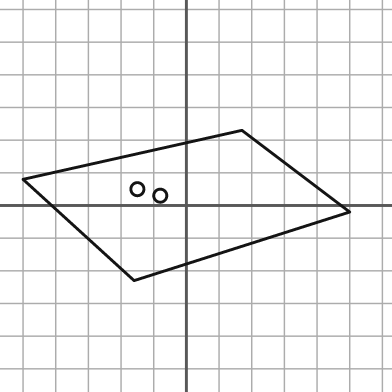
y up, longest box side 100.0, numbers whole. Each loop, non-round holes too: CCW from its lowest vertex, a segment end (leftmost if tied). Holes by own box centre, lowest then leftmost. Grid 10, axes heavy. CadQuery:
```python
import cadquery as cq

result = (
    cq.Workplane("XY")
    .moveTo(-16.0, -23.0)
    .lineTo(50.0, -2.0)
    .lineTo(17.0, 23.0)
    .lineTo(-50.0, 8.0)
    .close()
    .moveTo(-8.0, 3.0)
    .circle(2.0)
    .moveTo(-15.0, 5.0)
    .circle(2.0)
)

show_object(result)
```